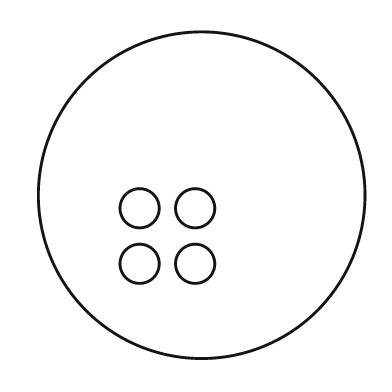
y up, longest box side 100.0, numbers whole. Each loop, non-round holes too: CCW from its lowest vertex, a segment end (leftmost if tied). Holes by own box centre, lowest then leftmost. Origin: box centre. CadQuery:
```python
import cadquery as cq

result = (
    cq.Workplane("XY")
    .moveTo(0.0, 0.0)
    .circle(50.0)
    .moveTo(-19.0, -21.0)
    .circle(6.0)
    .moveTo(-2.0, -21.0)
    .circle(6.0)
    .moveTo(-19.0, -4.0)
    .circle(6.0)
    .moveTo(-2.0, -4.0)
    .circle(6.0)
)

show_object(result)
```